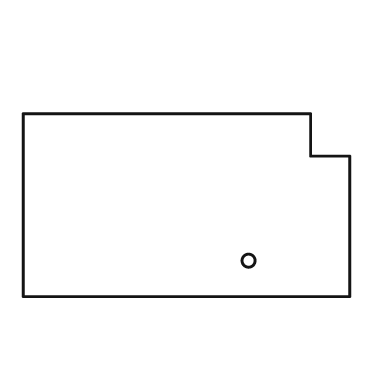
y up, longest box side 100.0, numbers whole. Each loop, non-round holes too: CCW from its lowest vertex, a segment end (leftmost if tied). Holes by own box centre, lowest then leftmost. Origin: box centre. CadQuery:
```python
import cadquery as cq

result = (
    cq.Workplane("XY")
    .moveTo(-50.0, -28.0)
    .lineTo(50.0, -28.0)
    .lineTo(50.0, 15.0)
    .lineTo(38.0, 15.0)
    .lineTo(38.0, 28.0)
    .lineTo(-50.0, 28.0)
    .close()
    .moveTo(19.0, -17.0)
    .circle(2.0)
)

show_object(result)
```